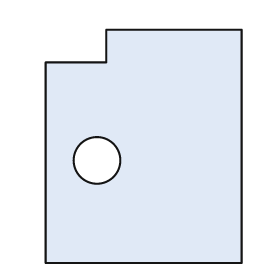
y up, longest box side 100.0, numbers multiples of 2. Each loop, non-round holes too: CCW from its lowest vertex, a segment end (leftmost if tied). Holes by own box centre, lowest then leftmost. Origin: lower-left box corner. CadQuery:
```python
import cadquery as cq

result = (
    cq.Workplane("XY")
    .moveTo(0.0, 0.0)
    .lineTo(84.0, 0.0)
    .lineTo(84.0, 100.0)
    .lineTo(26.0, 100.0)
    .lineTo(26.0, 86.0)
    .lineTo(0.0, 86.0)
    .close()
    .moveTo(22.0, 44.0)
    .circle(10.0)
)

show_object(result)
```